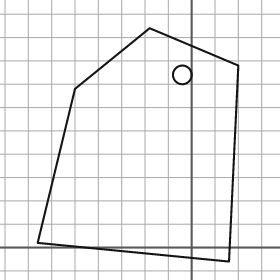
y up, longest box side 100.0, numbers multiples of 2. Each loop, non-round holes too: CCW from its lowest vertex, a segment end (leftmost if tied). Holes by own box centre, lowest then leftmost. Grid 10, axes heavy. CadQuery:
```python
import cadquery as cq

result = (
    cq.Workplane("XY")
    .moveTo(16.0, -6.0)
    .lineTo(20.0, 78.0)
    .lineTo(-18.0, 94.0)
    .lineTo(-50.0, 68.0)
    .lineTo(-66.0, 2.0)
    .close()
    .moveTo(-4.0, 74.0)
    .circle(4.0)
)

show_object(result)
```